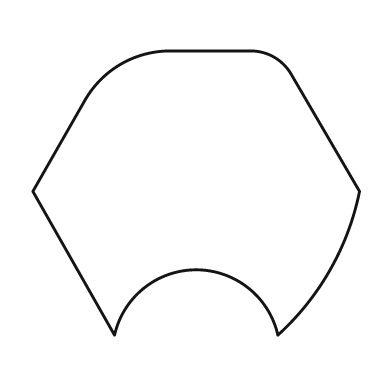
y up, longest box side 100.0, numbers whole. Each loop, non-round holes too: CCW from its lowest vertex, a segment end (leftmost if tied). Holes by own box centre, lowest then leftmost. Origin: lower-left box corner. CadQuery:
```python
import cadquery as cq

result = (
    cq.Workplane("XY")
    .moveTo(25.0, 0.0)
    .threePointArc((50.0, 20.0), (75.0, 0.0))
    .threePointArc((91.0, 20.0), (100.0, 44.0))
    .lineTo(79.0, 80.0)
    .threePointArc((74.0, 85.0), (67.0, 87.0))
    .lineTo(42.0, 87.0)
    .threePointArc((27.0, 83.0), (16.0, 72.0))
    .lineTo(0.0, 44.0)
    .close()
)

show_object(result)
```